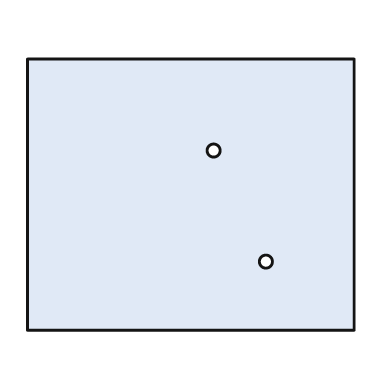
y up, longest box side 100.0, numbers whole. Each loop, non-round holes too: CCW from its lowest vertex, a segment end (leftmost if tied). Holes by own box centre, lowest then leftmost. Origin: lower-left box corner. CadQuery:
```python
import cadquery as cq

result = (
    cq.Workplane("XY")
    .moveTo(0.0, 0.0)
    .lineTo(100.0, 0.0)
    .lineTo(100.0, 83.0)
    .lineTo(0.0, 83.0)
    .close()
    .moveTo(73.0, 21.0)
    .circle(2.0)
    .moveTo(57.0, 55.0)
    .circle(2.0)
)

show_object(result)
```